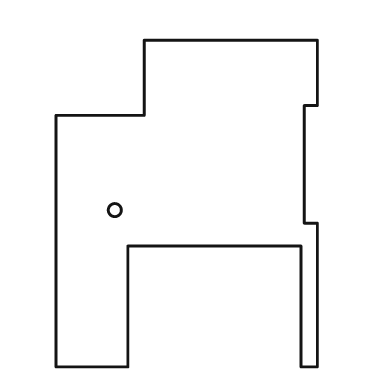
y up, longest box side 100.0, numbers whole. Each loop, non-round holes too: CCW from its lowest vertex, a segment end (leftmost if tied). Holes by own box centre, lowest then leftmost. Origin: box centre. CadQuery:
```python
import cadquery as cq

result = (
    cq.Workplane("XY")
    .moveTo(-40.0, -50.0)
    .lineTo(-18.0, -50.0)
    .lineTo(-18.0, -13.0)
    .lineTo(35.0, -13.0)
    .lineTo(35.0, -50.0)
    .lineTo(40.0, -50.0)
    .lineTo(40.0, -6.0)
    .lineTo(36.0, -6.0)
    .lineTo(36.0, 30.0)
    .lineTo(40.0, 30.0)
    .lineTo(40.0, 50.0)
    .lineTo(-13.0, 50.0)
    .lineTo(-13.0, 27.0)
    .lineTo(-40.0, 27.0)
    .close()
    .moveTo(-22.0, -2.0)
    .circle(2.0)
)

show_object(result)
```